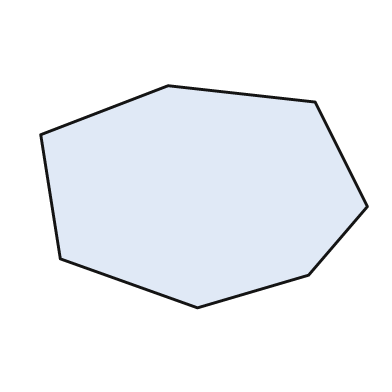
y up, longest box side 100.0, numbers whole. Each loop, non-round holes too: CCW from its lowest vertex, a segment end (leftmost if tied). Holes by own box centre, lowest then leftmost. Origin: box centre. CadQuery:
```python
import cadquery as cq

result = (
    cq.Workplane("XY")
    .moveTo(-2.0, -34.0)
    .lineTo(32.0, -24.0)
    .lineTo(50.0, -3.0)
    .lineTo(34.0, 29.0)
    .lineTo(-11.0, 34.0)
    .lineTo(-50.0, 19.0)
    .lineTo(-44.0, -19.0)
    .close()
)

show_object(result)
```